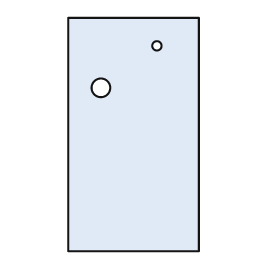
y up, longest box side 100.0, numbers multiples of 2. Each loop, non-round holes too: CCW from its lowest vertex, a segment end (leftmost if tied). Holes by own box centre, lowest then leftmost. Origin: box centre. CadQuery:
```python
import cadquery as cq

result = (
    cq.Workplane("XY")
    .moveTo(-28.0, -50.0)
    .lineTo(28.0, -50.0)
    .lineTo(28.0, 50.0)
    .lineTo(-28.0, 50.0)
    .close()
    .moveTo(-14.0, 20.0)
    .circle(4.0)
    .moveTo(10.0, 38.0)
    .circle(2.0)
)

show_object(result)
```